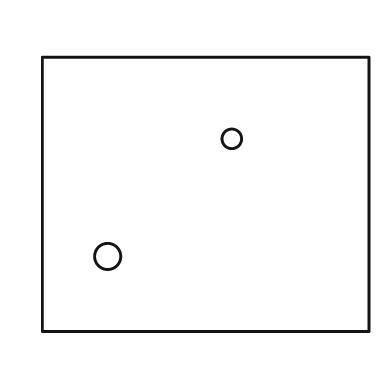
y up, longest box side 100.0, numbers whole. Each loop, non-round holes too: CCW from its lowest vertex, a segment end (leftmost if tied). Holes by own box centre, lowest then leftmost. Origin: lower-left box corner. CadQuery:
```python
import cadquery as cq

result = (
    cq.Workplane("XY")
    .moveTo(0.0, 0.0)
    .lineTo(100.0, 0.0)
    .lineTo(100.0, 84.0)
    .lineTo(0.0, 84.0)
    .close()
    .moveTo(20.0, 23.0)
    .circle(4.0)
    .moveTo(58.0, 59.0)
    .circle(3.0)
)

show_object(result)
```